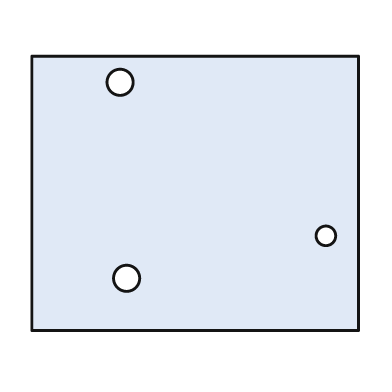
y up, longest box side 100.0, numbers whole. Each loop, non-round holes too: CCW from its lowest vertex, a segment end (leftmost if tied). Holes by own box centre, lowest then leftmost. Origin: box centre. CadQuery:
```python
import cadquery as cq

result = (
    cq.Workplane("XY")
    .moveTo(-50.0, -42.0)
    .lineTo(50.0, -42.0)
    .lineTo(50.0, 42.0)
    .lineTo(-50.0, 42.0)
    .close()
    .moveTo(-21.0, -26.0)
    .circle(4.0)
    .moveTo(40.0, -13.0)
    .circle(3.0)
    .moveTo(-23.0, 34.0)
    .circle(4.0)
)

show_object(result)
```